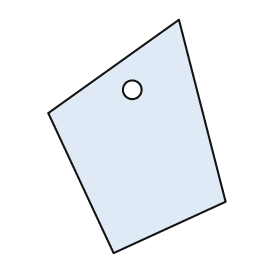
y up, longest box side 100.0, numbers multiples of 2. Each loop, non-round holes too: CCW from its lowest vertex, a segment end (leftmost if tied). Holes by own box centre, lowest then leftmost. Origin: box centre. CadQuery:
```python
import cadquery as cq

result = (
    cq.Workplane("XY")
    .moveTo(-10.0, -50.0)
    .lineTo(38.0, -28.0)
    .lineTo(18.0, 50.0)
    .lineTo(-38.0, 10.0)
    .close()
    .moveTo(-2.0, 20.0)
    .circle(4.0)
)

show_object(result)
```